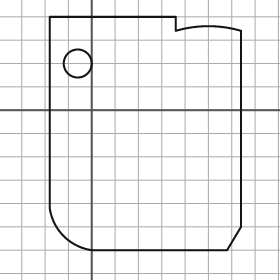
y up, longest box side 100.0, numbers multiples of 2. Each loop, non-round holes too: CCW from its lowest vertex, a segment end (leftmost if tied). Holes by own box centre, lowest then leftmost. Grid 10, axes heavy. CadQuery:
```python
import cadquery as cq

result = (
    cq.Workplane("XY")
    .moveTo(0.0, -60.0)
    .lineTo(58.0, -60.0)
    .lineTo(64.0, -50.0)
    .lineTo(64.0, 34.0)
    .threePointArc((50.0, 36.0), (36.0, 34.0))
    .lineTo(36.0, 40.0)
    .lineTo(-18.0, 40.0)
    .lineTo(-18.0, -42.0)
    .threePointArc((-12.0, -54.0), (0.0, -60.0))
    .close()
    .moveTo(-6.0, 20.0)
    .circle(6.0)
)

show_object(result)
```